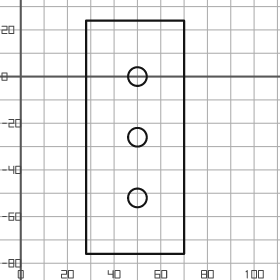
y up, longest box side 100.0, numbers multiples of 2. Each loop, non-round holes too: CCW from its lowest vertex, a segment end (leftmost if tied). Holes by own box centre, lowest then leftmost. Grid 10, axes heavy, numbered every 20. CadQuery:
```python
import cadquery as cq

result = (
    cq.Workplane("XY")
    .moveTo(28.0, -76.0)
    .lineTo(70.0, -76.0)
    .lineTo(70.0, 24.0)
    .lineTo(28.0, 24.0)
    .close()
    .moveTo(50.0, -52.0)
    .circle(4.0)
    .moveTo(50.0, -26.0)
    .circle(4.0)
    .moveTo(50.0, 0.0)
    .circle(4.0)
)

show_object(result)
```